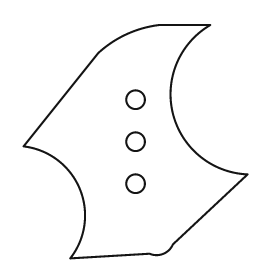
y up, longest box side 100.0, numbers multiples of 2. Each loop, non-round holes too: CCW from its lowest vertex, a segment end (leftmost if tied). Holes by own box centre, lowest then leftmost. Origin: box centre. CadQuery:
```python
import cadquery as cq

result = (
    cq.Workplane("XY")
    .moveTo(-28.0, -50.0)
    .lineTo(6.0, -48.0)
    .threePointArc((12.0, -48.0), (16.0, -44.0))
    .lineTo(48.0, -14.0)
    .threePointArc((16.0, 12.0), (32.0, 50.0))
    .lineTo(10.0, 50.0)
    .threePointArc((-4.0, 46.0), (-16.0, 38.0))
    .lineTo(-48.0, -2.0)
    .threePointArc((-24.0, -20.0), (-28.0, -50.0))
    .close()
    .moveTo(0.0, -18.0)
    .circle(4.0)
    .moveTo(0.0, 0.0)
    .circle(4.0)
    .moveTo(0.0, 18.0)
    .circle(4.0)
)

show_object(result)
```